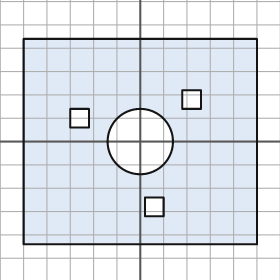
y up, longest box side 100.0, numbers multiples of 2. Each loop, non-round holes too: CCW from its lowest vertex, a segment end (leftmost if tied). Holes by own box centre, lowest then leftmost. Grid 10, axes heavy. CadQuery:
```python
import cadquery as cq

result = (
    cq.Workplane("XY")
    .moveTo(-50.0, -44.0)
    .lineTo(50.0, -44.0)
    .lineTo(50.0, 44.0)
    .lineTo(-50.0, 44.0)
    .close()
    .moveTo(2.0, -32.0)
    .lineTo(10.0, -32.0)
    .lineTo(10.0, -24.0)
    .lineTo(2.0, -24.0)
    .close()
    .moveTo(0.0, 0.0)
    .circle(14.0)
    .moveTo(-30.0, 6.0)
    .lineTo(-22.0, 6.0)
    .lineTo(-22.0, 14.0)
    .lineTo(-30.0, 14.0)
    .close()
    .moveTo(18.0, 14.0)
    .lineTo(26.0, 14.0)
    .lineTo(26.0, 22.0)
    .lineTo(18.0, 22.0)
    .close()
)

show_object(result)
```